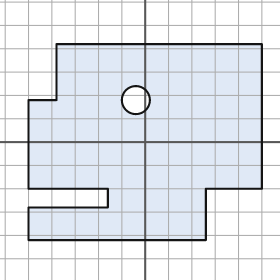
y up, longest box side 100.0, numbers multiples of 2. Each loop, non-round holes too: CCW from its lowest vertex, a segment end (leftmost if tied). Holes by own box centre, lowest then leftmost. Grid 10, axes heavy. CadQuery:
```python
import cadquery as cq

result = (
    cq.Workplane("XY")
    .moveTo(-50.0, -42.0)
    .lineTo(26.0, -42.0)
    .lineTo(26.0, -20.0)
    .lineTo(50.0, -20.0)
    .lineTo(50.0, 42.0)
    .lineTo(-38.0, 42.0)
    .lineTo(-38.0, 18.0)
    .lineTo(-50.0, 18.0)
    .lineTo(-50.0, -20.0)
    .lineTo(-16.0, -20.0)
    .lineTo(-16.0, -28.0)
    .lineTo(-50.0, -28.0)
    .close()
    .moveTo(-4.0, 18.0)
    .circle(6.0)
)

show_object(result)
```